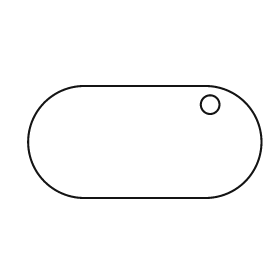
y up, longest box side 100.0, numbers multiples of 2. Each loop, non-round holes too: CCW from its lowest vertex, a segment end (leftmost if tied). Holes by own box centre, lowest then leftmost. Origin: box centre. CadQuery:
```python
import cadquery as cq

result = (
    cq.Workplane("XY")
    .moveTo(-26.0, -24.0)
    .lineTo(26.0, -24.0)
    .threePointArc((50.0, 0.0), (26.0, 24.0))
    .lineTo(-26.0, 24.0)
    .threePointArc((-50.0, 0.0), (-26.0, -24.0))
    .close()
    .moveTo(28.0, 16.0)
    .circle(4.0)
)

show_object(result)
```